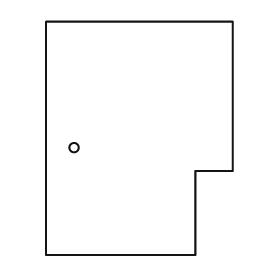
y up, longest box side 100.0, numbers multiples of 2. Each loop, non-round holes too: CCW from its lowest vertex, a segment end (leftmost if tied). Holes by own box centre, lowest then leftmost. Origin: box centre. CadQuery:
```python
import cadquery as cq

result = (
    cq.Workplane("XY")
    .moveTo(-40.0, -50.0)
    .lineTo(24.0, -50.0)
    .lineTo(24.0, -14.0)
    .lineTo(40.0, -14.0)
    .lineTo(40.0, 50.0)
    .lineTo(-40.0, 50.0)
    .close()
    .moveTo(-28.0, -4.0)
    .circle(2.0)
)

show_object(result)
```